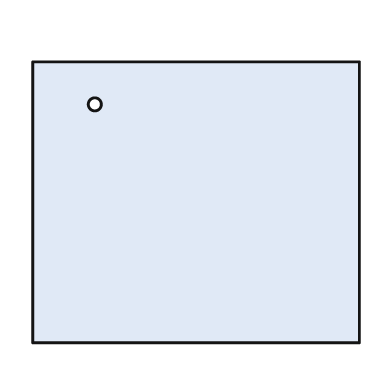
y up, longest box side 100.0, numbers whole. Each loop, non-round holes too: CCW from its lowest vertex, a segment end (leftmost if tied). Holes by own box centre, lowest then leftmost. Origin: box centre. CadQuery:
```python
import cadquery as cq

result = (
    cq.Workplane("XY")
    .moveTo(-50.0, -43.0)
    .lineTo(50.0, -43.0)
    .lineTo(50.0, 43.0)
    .lineTo(-50.0, 43.0)
    .close()
    .moveTo(-31.0, 30.0)
    .circle(2.0)
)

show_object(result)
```